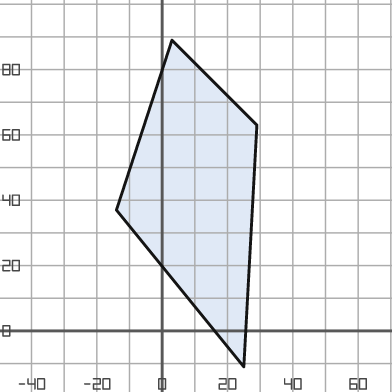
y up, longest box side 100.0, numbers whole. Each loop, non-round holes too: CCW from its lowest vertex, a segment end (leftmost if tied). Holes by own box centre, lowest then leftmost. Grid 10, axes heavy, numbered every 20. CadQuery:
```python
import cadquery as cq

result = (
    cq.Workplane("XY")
    .moveTo(25.0, -11.0)
    .lineTo(29.0, 63.0)
    .lineTo(3.0, 89.0)
    .lineTo(-14.0, 37.0)
    .close()
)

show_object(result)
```